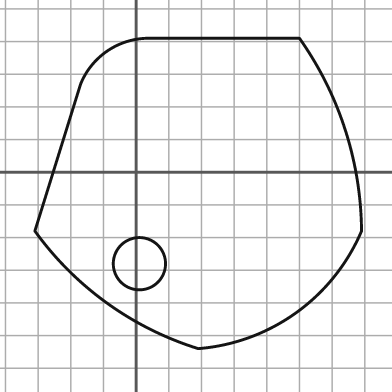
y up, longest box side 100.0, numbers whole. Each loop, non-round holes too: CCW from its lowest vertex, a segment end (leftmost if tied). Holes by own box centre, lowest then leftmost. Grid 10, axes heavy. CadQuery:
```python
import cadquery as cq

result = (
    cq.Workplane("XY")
    .moveTo(19.0, -54.0)
    .threePointArc((49.0, -43.0), (69.0, -18.0))
    .threePointArc((64.0, 13.0), (50.0, 41.0))
    .lineTo(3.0, 41.0)
    .threePointArc((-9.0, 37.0), (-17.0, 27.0))
    .lineTo(-31.0, -18.0)
    .threePointArc((-9.0, -40.0), (19.0, -54.0))
    .close()
    .moveTo(1.0, -28.0)
    .circle(8.0)
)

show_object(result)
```